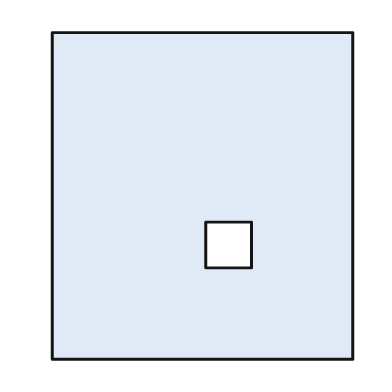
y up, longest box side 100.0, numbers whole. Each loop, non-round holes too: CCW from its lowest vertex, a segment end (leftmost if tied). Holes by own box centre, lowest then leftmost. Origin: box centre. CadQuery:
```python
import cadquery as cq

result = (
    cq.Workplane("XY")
    .moveTo(-46.0, -50.0)
    .lineTo(46.0, -50.0)
    .lineTo(46.0, 50.0)
    .lineTo(-46.0, 50.0)
    .close()
    .moveTo(1.0, -22.0)
    .lineTo(15.0, -22.0)
    .lineTo(15.0, -8.0)
    .lineTo(1.0, -8.0)
    .close()
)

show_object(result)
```